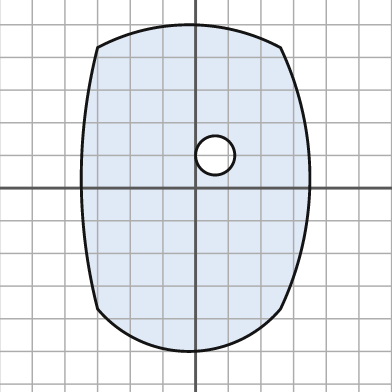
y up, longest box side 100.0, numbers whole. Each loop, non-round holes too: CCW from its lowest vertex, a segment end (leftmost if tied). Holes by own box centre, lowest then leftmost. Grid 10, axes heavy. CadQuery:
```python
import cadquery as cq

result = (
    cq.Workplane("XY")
    .moveTo(-30.0, -37.0)
    .threePointArc((-2.0, -50.0), (26.0, -37.0))
    .threePointArc((35.0, 3.0), (26.0, 43.0))
    .threePointArc((-2.0, 50.0), (-30.0, 43.0))
    .threePointArc((-35.0, 3.0), (-30.0, -37.0))
    .close()
    .moveTo(6.0, 10.0)
    .circle(6.0)
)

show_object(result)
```